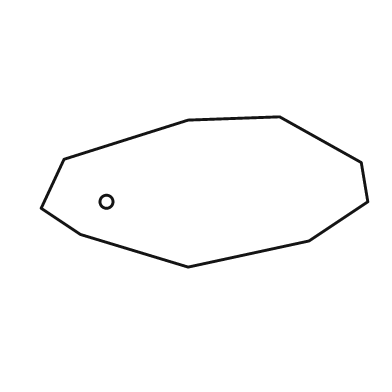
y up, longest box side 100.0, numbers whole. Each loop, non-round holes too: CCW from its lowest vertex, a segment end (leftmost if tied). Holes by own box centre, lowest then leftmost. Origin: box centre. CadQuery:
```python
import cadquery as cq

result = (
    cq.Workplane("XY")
    .moveTo(-5.0, -23.0)
    .lineTo(32.0, -15.0)
    .lineTo(50.0, -3.0)
    .lineTo(48.0, 9.0)
    .lineTo(23.0, 23.0)
    .lineTo(-5.0, 22.0)
    .lineTo(-43.0, 10.0)
    .lineTo(-50.0, -5.0)
    .lineTo(-38.0, -13.0)
    .close()
    .moveTo(-30.0, -3.0)
    .circle(2.0)
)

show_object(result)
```